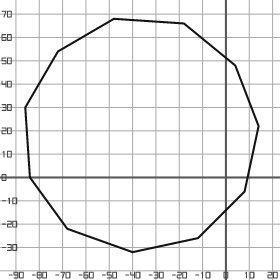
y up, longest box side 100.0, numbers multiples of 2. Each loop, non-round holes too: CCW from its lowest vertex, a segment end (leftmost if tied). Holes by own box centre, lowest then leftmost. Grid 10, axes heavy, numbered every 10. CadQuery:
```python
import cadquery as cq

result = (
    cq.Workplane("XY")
    .moveTo(-40.0, -32.0)
    .lineTo(-12.0, -26.0)
    .lineTo(8.0, -6.0)
    .lineTo(14.0, 22.0)
    .lineTo(4.0, 48.0)
    .lineTo(-18.0, 66.0)
    .lineTo(-48.0, 68.0)
    .lineTo(-72.0, 54.0)
    .lineTo(-86.0, 30.0)
    .lineTo(-84.0, 0.0)
    .lineTo(-68.0, -22.0)
    .close()
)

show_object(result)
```